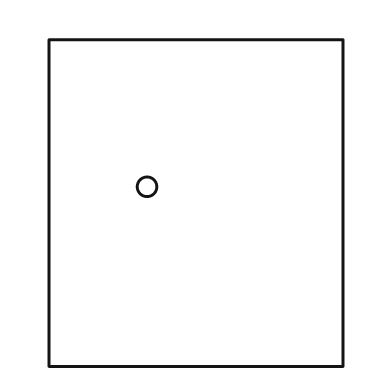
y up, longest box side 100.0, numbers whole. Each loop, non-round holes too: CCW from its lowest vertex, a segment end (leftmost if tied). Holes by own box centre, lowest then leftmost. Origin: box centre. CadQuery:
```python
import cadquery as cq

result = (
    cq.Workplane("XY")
    .moveTo(-45.0, -50.0)
    .lineTo(45.0, -50.0)
    .lineTo(45.0, 50.0)
    .lineTo(-45.0, 50.0)
    .close()
    .moveTo(-15.0, 5.0)
    .circle(3.0)
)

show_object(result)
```